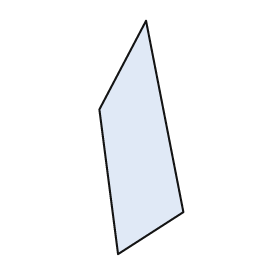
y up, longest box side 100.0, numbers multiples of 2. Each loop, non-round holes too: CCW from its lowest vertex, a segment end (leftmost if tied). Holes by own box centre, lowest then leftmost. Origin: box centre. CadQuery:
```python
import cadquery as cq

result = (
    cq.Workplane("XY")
    .moveTo(-10.0, -50.0)
    .lineTo(18.0, -32.0)
    .lineTo(2.0, 50.0)
    .lineTo(-18.0, 12.0)
    .close()
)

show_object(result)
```